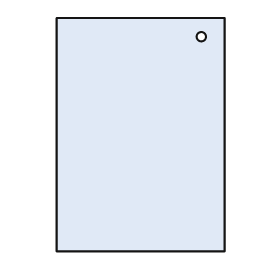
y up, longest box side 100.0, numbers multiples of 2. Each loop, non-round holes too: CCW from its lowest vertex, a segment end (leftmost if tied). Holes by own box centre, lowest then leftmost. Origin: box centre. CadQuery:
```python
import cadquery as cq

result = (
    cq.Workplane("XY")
    .moveTo(-36.0, -50.0)
    .lineTo(36.0, -50.0)
    .lineTo(36.0, 50.0)
    .lineTo(-36.0, 50.0)
    .close()
    .moveTo(26.0, 42.0)
    .circle(2.0)
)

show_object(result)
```